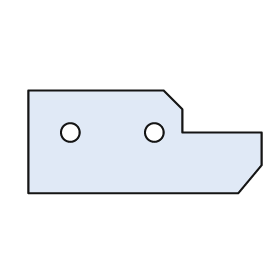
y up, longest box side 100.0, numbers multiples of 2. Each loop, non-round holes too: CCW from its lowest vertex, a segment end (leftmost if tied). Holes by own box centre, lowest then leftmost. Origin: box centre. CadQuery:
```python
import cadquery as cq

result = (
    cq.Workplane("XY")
    .moveTo(-50.0, -22.0)
    .lineTo(40.0, -22.0)
    .lineTo(50.0, -10.0)
    .lineTo(50.0, 4.0)
    .lineTo(16.0, 4.0)
    .lineTo(16.0, 14.0)
    .lineTo(8.0, 22.0)
    .lineTo(-50.0, 22.0)
    .close()
    .moveTo(-32.0, 4.0)
    .circle(4.0)
    .moveTo(4.0, 4.0)
    .circle(4.0)
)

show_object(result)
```